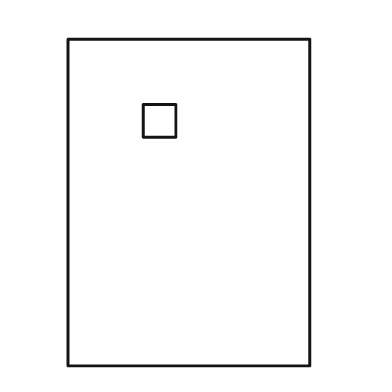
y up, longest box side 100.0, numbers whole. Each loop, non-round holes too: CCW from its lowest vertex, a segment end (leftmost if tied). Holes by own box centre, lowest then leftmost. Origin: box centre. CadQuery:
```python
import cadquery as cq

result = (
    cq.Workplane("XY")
    .moveTo(-37.0, -50.0)
    .lineTo(37.0, -50.0)
    .lineTo(37.0, 50.0)
    .lineTo(-37.0, 50.0)
    .close()
    .moveTo(-14.0, 20.0)
    .lineTo(-4.0, 20.0)
    .lineTo(-4.0, 30.0)
    .lineTo(-14.0, 30.0)
    .close()
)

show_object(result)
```